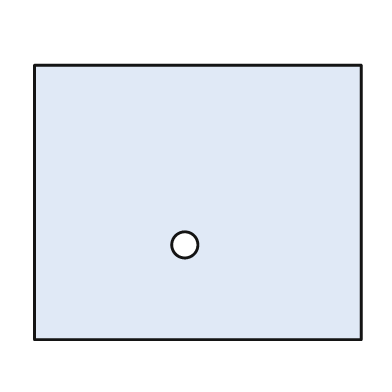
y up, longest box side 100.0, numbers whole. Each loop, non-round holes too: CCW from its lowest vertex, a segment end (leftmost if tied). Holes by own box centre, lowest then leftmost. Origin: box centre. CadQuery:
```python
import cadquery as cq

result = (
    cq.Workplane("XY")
    .moveTo(-50.0, -42.0)
    .lineTo(50.0, -42.0)
    .lineTo(50.0, 42.0)
    .lineTo(-50.0, 42.0)
    .close()
    .moveTo(-4.0, -13.0)
    .circle(4.0)
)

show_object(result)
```